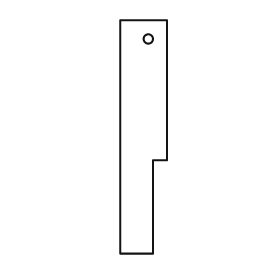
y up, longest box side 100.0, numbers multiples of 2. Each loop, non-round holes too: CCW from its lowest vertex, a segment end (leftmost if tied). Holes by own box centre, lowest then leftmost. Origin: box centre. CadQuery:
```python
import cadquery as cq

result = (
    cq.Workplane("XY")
    .moveTo(-10.0, -50.0)
    .lineTo(4.0, -50.0)
    .lineTo(4.0, -10.0)
    .lineTo(10.0, -10.0)
    .lineTo(10.0, 50.0)
    .lineTo(-10.0, 50.0)
    .close()
    .moveTo(2.0, 42.0)
    .circle(2.0)
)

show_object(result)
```